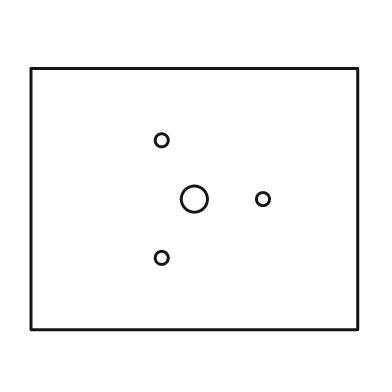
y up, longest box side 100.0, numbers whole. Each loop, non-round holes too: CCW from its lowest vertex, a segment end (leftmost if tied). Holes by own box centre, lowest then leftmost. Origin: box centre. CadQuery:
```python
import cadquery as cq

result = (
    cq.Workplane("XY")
    .moveTo(-50.0, -40.0)
    .lineTo(50.0, -40.0)
    .lineTo(50.0, 40.0)
    .lineTo(-50.0, 40.0)
    .close()
    .moveTo(-10.0, -18.0)
    .circle(2.0)
    .moveTo(0.0, 0.0)
    .circle(4.0)
    .moveTo(21.0, 0.0)
    .circle(2.0)
    .moveTo(-10.0, 18.0)
    .circle(2.0)
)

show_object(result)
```